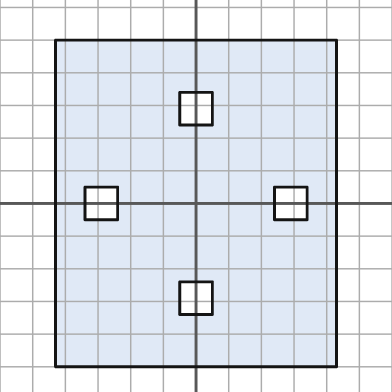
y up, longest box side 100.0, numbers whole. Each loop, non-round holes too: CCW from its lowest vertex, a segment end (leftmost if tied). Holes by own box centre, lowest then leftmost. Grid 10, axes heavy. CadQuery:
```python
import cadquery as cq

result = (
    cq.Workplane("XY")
    .moveTo(-43.0, -50.0)
    .lineTo(43.0, -50.0)
    .lineTo(43.0, 50.0)
    .lineTo(-43.0, 50.0)
    .close()
    .moveTo(-5.0, -34.0)
    .lineTo(5.0, -34.0)
    .lineTo(5.0, -24.0)
    .lineTo(-5.0, -24.0)
    .close()
    .moveTo(-34.0, -5.0)
    .lineTo(-24.0, -5.0)
    .lineTo(-24.0, 5.0)
    .lineTo(-34.0, 5.0)
    .close()
    .moveTo(24.0, -5.0)
    .lineTo(34.0, -5.0)
    .lineTo(34.0, 5.0)
    .lineTo(24.0, 5.0)
    .close()
    .moveTo(-5.0, 24.0)
    .lineTo(5.0, 24.0)
    .lineTo(5.0, 34.0)
    .lineTo(-5.0, 34.0)
    .close()
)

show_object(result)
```